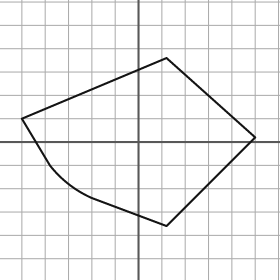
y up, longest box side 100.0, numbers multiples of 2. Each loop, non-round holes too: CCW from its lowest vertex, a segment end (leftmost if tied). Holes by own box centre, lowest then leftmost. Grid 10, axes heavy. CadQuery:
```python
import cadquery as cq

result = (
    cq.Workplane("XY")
    .moveTo(12.0, -36.0)
    .lineTo(50.0, 2.0)
    .lineTo(12.0, 36.0)
    .lineTo(-50.0, 10.0)
    .lineTo(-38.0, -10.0)
    .threePointArc((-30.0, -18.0), (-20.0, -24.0))
    .close()
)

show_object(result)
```